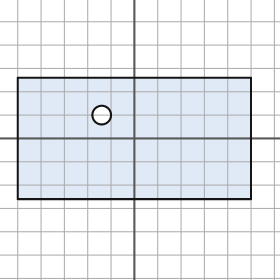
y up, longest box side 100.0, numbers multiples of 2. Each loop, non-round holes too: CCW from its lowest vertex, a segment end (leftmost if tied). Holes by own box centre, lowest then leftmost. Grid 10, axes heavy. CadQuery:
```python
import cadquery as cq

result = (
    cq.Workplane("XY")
    .moveTo(-50.0, -26.0)
    .lineTo(50.0, -26.0)
    .lineTo(50.0, 26.0)
    .lineTo(-50.0, 26.0)
    .close()
    .moveTo(-14.0, 10.0)
    .circle(4.0)
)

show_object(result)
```